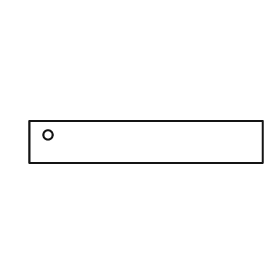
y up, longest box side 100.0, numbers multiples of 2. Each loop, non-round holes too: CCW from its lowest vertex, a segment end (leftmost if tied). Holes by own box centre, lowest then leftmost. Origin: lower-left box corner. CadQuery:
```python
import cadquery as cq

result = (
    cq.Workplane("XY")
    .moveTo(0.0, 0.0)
    .lineTo(100.0, 0.0)
    .lineTo(100.0, 18.0)
    .lineTo(0.0, 18.0)
    .close()
    .moveTo(8.0, 12.0)
    .circle(2.0)
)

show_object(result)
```